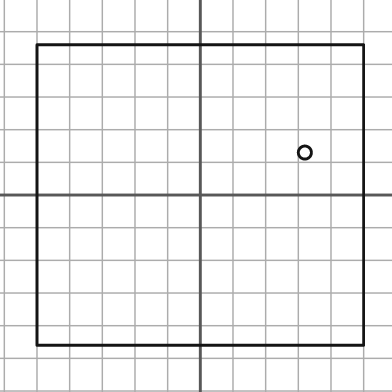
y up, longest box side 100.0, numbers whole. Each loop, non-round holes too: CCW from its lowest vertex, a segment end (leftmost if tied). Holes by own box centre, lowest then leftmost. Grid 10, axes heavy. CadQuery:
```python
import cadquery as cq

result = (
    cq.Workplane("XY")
    .moveTo(-50.0, -46.0)
    .lineTo(50.0, -46.0)
    .lineTo(50.0, 46.0)
    .lineTo(-50.0, 46.0)
    .close()
    .moveTo(32.0, 13.0)
    .circle(2.0)
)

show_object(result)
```